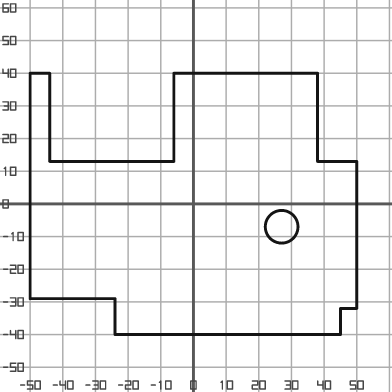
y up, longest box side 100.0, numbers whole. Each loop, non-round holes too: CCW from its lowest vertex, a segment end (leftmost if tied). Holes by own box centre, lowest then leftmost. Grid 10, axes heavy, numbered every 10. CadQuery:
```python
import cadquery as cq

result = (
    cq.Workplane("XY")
    .moveTo(-24.0, -40.0)
    .lineTo(45.0, -40.0)
    .lineTo(45.0, -32.0)
    .lineTo(50.0, -32.0)
    .lineTo(50.0, 13.0)
    .lineTo(38.0, 13.0)
    .lineTo(38.0, 40.0)
    .lineTo(-6.0, 40.0)
    .lineTo(-6.0, 13.0)
    .lineTo(-44.0, 13.0)
    .lineTo(-44.0, 40.0)
    .lineTo(-50.0, 40.0)
    .lineTo(-50.0, -29.0)
    .lineTo(-24.0, -29.0)
    .close()
    .moveTo(27.0, -7.0)
    .circle(5.0)
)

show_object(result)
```